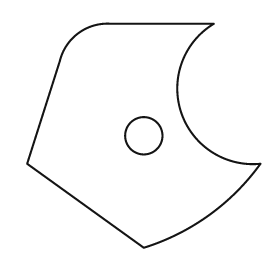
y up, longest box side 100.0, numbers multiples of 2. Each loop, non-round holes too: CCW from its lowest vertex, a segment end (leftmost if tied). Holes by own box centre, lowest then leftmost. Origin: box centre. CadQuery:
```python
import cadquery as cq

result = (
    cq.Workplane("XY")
    .moveTo(0.0, -48.0)
    .threePointArc((28.0, -34.0), (50.0, -12.0))
    .threePointArc((16.0, 10.0), (30.0, 48.0))
    .lineTo(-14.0, 48.0)
    .threePointArc((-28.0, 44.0), (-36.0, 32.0))
    .lineTo(-50.0, -12.0)
    .close()
    .moveTo(0.0, 0.0)
    .circle(8.0)
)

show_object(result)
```